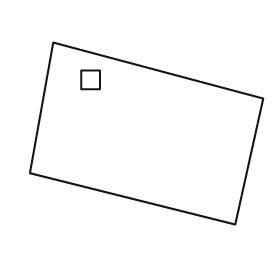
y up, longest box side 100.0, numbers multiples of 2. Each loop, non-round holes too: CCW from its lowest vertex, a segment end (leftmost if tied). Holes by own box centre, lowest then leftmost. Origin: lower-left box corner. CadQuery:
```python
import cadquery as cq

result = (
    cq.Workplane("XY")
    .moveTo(88.0, 0.0)
    .lineTo(100.0, 54.0)
    .lineTo(10.0, 78.0)
    .lineTo(0.0, 22.0)
    .close()
    .moveTo(22.0, 58.0)
    .lineTo(30.0, 58.0)
    .lineTo(30.0, 66.0)
    .lineTo(22.0, 66.0)
    .close()
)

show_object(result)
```